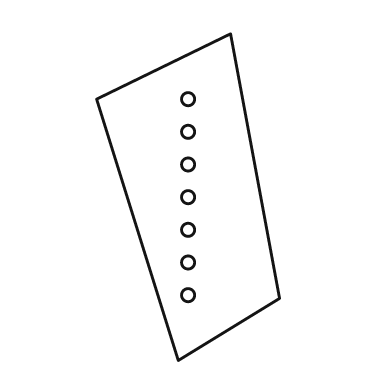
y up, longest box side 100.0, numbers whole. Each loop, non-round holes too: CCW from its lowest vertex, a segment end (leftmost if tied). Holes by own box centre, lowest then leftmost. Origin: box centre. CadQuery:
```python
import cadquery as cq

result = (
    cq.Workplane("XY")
    .moveTo(-3.0, -50.0)
    .lineTo(28.0, -31.0)
    .lineTo(13.0, 50.0)
    .lineTo(-28.0, 30.0)
    .close()
    .moveTo(0.0, -30.0)
    .circle(2.0)
    .moveTo(0.0, -20.0)
    .circle(2.0)
    .moveTo(0.0, -10.0)
    .circle(2.0)
    .moveTo(0.0, 0.0)
    .circle(2.0)
    .moveTo(0.0, 10.0)
    .circle(2.0)
    .moveTo(0.0, 20.0)
    .circle(2.0)
    .moveTo(0.0, 30.0)
    .circle(2.0)
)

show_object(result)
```